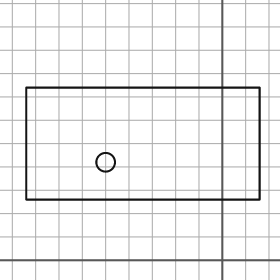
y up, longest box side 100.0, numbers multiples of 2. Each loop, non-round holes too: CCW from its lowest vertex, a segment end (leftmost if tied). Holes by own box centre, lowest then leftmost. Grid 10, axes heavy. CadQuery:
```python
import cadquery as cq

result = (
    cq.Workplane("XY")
    .moveTo(-84.0, 26.0)
    .lineTo(16.0, 26.0)
    .lineTo(16.0, 74.0)
    .lineTo(-84.0, 74.0)
    .close()
    .moveTo(-50.0, 42.0)
    .circle(4.0)
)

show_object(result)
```